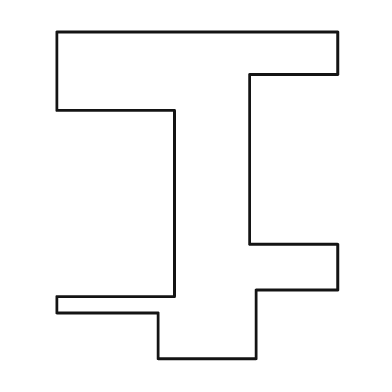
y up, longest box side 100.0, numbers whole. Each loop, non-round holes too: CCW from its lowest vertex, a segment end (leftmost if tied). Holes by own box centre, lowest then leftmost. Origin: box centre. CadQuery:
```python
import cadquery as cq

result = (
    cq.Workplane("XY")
    .moveTo(-12.0, -50.0)
    .lineTo(18.0, -50.0)
    .lineTo(18.0, -29.0)
    .lineTo(43.0, -29.0)
    .lineTo(43.0, -15.0)
    .lineTo(16.0, -15.0)
    .lineTo(16.0, 37.0)
    .lineTo(43.0, 37.0)
    .lineTo(43.0, 50.0)
    .lineTo(-43.0, 50.0)
    .lineTo(-43.0, 26.0)
    .lineTo(-7.0, 26.0)
    .lineTo(-7.0, -31.0)
    .lineTo(-43.0, -31.0)
    .lineTo(-43.0, -36.0)
    .lineTo(-12.0, -36.0)
    .close()
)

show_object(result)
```